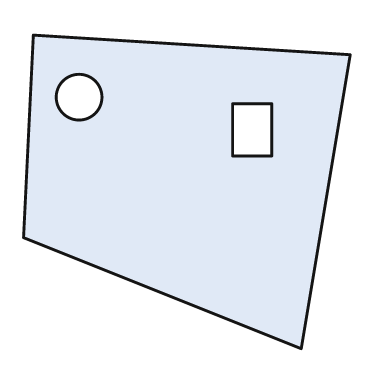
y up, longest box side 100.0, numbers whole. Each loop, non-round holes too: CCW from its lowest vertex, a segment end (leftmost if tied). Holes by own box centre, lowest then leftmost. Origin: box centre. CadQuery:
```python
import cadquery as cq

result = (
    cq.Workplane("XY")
    .moveTo(35.0, -48.0)
    .lineTo(50.0, 42.0)
    .lineTo(-47.0, 48.0)
    .lineTo(-50.0, -14.0)
    .close()
    .moveTo(14.0, 11.0)
    .lineTo(26.0, 11.0)
    .lineTo(26.0, 27.0)
    .lineTo(14.0, 27.0)
    .close()
    .moveTo(-33.0, 29.0)
    .circle(7.0)
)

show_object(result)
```